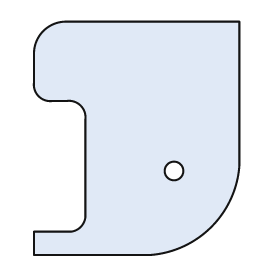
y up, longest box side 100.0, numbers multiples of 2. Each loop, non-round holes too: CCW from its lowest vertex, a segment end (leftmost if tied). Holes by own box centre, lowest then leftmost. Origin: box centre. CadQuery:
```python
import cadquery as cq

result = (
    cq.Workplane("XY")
    .moveTo(-44.0, -50.0)
    .lineTo(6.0, -50.0)
    .threePointArc((32.0, -38.0), (44.0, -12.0))
    .lineTo(44.0, 50.0)
    .lineTo(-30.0, 50.0)
    .threePointArc((-40.0, 46.0), (-44.0, 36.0))
    .lineTo(-44.0, 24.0)
    .threePointArc((-42.0, 18.0), (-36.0, 16.0))
    .lineTo(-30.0, 16.0)
    .threePointArc((-24.0, 14.0), (-22.0, 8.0))
    .lineTo(-22.0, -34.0)
    .threePointArc((-24.0, -38.0), (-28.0, -40.0))
    .lineTo(-44.0, -40.0)
    .close()
    .moveTo(16.0, -14.0)
    .circle(4.0)
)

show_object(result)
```